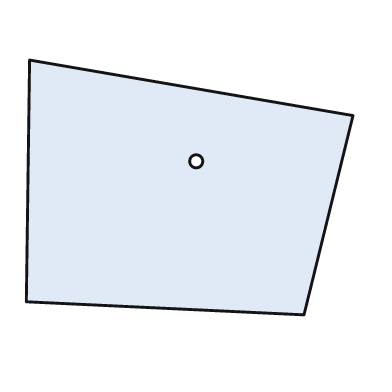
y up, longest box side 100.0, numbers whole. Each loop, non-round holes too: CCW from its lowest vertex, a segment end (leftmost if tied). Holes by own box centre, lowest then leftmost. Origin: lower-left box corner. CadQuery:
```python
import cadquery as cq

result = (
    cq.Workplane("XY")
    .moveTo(85.0, 0.0)
    .lineTo(100.0, 61.0)
    .lineTo(1.0, 78.0)
    .lineTo(0.0, 4.0)
    .close()
    .moveTo(52.0, 47.0)
    .circle(2.0)
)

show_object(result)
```